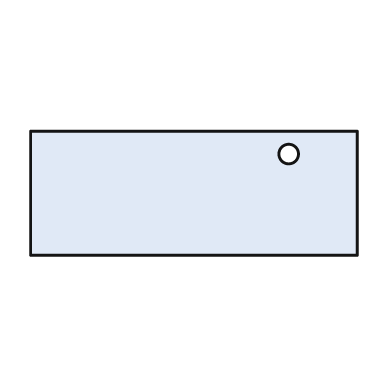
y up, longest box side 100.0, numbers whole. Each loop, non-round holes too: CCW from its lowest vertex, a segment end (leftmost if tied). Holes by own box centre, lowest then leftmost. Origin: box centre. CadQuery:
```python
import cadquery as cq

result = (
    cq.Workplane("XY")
    .moveTo(-50.0, -19.0)
    .lineTo(50.0, -19.0)
    .lineTo(50.0, 19.0)
    .lineTo(-50.0, 19.0)
    .close()
    .moveTo(29.0, 12.0)
    .circle(3.0)
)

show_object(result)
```